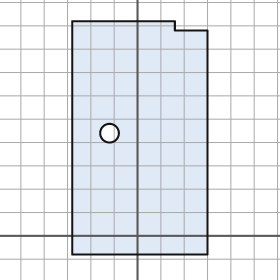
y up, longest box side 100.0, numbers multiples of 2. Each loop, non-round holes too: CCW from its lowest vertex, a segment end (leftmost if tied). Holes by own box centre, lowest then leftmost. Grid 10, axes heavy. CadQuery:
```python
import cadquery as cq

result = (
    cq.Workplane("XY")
    .moveTo(-28.0, -8.0)
    .lineTo(30.0, -8.0)
    .lineTo(30.0, 88.0)
    .lineTo(16.0, 88.0)
    .lineTo(16.0, 92.0)
    .lineTo(-28.0, 92.0)
    .close()
    .moveTo(-12.0, 44.0)
    .circle(4.0)
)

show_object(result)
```